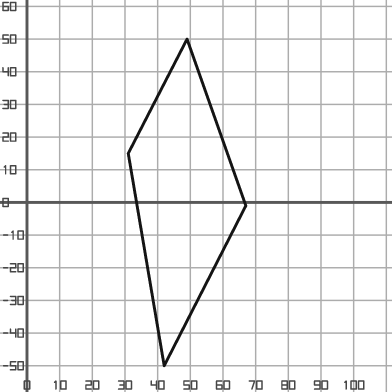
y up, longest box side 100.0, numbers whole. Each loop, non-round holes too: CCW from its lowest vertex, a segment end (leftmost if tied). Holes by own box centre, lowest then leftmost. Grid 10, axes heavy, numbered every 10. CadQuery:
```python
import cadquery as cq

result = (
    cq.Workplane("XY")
    .moveTo(42.0, -50.0)
    .lineTo(67.0, -1.0)
    .lineTo(49.0, 50.0)
    .lineTo(31.0, 15.0)
    .close()
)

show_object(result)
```